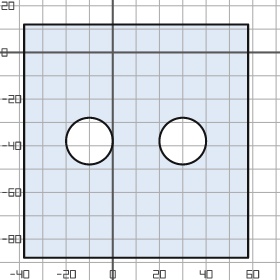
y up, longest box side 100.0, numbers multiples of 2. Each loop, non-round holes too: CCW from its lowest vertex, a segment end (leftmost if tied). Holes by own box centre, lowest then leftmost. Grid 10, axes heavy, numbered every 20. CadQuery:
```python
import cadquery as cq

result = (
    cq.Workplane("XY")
    .moveTo(-38.0, -88.0)
    .lineTo(58.0, -88.0)
    .lineTo(58.0, 12.0)
    .lineTo(-38.0, 12.0)
    .close()
    .moveTo(-10.0, -38.0)
    .circle(10.0)
    .moveTo(30.0, -38.0)
    .circle(10.0)
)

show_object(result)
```